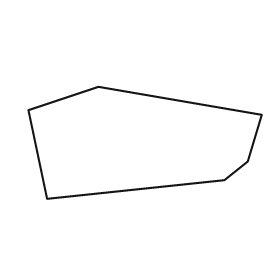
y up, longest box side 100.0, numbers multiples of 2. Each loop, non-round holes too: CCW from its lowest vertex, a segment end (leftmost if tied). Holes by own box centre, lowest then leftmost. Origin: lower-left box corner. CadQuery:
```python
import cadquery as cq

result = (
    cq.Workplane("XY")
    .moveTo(8.0, 0.0)
    .lineTo(84.0, 8.0)
    .lineTo(94.0, 16.0)
    .lineTo(100.0, 36.0)
    .lineTo(30.0, 48.0)
    .lineTo(0.0, 38.0)
    .close()
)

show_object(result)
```